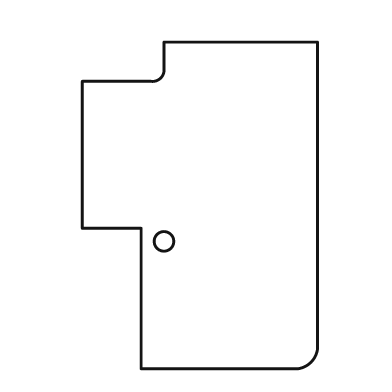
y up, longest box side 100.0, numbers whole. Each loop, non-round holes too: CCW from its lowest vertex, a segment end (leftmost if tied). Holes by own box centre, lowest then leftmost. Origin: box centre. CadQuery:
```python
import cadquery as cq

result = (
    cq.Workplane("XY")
    .moveTo(-18.0, -50.0)
    .lineTo(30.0, -50.0)
    .threePointArc((34.0, -48.0), (36.0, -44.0))
    .lineTo(36.0, 50.0)
    .lineTo(-11.0, 50.0)
    .lineTo(-11.0, 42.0)
    .threePointArc((-12.0, 39.0), (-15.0, 38.0))
    .lineTo(-36.0, 38.0)
    .lineTo(-36.0, -7.0)
    .lineTo(-18.0, -7.0)
    .close()
    .moveTo(-11.0, -11.0)
    .circle(3.0)
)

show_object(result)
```